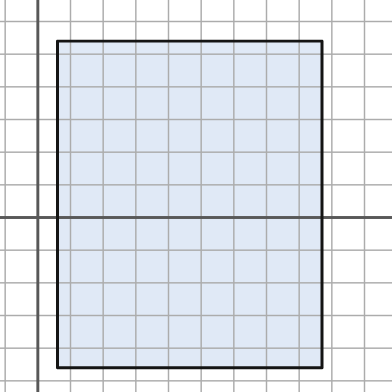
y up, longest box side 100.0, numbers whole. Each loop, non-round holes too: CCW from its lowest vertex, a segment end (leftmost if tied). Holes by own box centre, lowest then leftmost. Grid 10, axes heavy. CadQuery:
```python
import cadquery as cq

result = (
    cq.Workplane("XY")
    .moveTo(6.0, -46.0)
    .lineTo(87.0, -46.0)
    .lineTo(87.0, 54.0)
    .lineTo(6.0, 54.0)
    .close()
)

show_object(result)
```